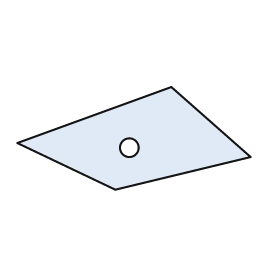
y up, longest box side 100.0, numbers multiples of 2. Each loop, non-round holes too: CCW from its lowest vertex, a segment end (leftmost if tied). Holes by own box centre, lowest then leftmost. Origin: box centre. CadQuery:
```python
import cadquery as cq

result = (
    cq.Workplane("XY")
    .moveTo(-8.0, -22.0)
    .lineTo(50.0, -8.0)
    .lineTo(16.0, 22.0)
    .lineTo(-50.0, -2.0)
    .close()
    .moveTo(-2.0, -4.0)
    .circle(4.0)
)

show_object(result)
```